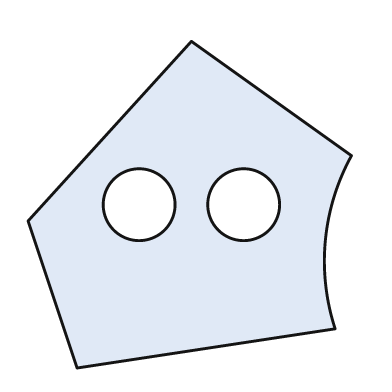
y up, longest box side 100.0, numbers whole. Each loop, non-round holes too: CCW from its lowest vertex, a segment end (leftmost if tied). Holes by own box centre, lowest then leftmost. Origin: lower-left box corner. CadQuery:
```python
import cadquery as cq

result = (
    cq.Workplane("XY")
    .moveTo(15.0, 0.0)
    .lineTo(94.0, 12.0)
    .threePointArc((91.0, 39.0), (99.0, 65.0))
    .lineTo(50.0, 100.0)
    .lineTo(0.0, 45.0)
    .close()
    .moveTo(34.0, 50.0)
    .circle(11.0)
    .moveTo(66.0, 50.0)
    .circle(11.0)
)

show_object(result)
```